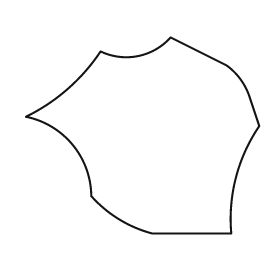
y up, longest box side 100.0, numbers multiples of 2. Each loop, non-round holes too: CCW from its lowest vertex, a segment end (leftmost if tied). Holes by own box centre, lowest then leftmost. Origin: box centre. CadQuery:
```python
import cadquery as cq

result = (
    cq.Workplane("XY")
    .moveTo(4.0, -42.0)
    .lineTo(38.0, -42.0)
    .threePointArc((40.0, -18.0), (50.0, 4.0))
    .lineTo(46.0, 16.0)
    .threePointArc((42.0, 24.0), (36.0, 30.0))
    .lineTo(12.0, 42.0)
    .threePointArc((-2.0, 34.0), (-18.0, 36.0))
    .threePointArc((-32.0, 20.0), (-50.0, 8.0))
    .threePointArc((-30.0, -4.0), (-22.0, -26.0))
    .threePointArc((-10.0, -36.0), (4.0, -42.0))
    .close()
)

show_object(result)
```